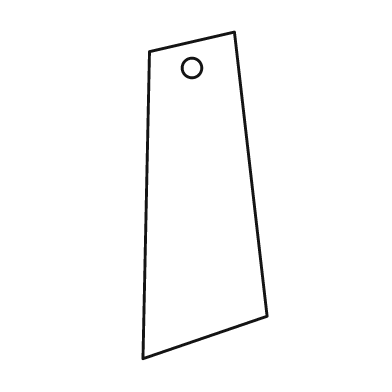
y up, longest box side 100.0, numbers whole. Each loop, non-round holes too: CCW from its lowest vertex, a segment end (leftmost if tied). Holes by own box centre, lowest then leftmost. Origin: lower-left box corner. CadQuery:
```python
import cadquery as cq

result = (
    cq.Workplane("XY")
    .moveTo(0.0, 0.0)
    .lineTo(38.0, 13.0)
    .lineTo(28.0, 100.0)
    .lineTo(2.0, 94.0)
    .close()
    .moveTo(15.0, 89.0)
    .circle(3.0)
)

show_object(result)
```